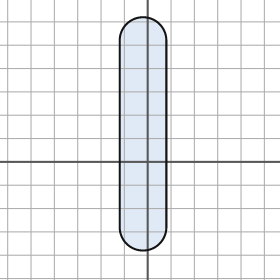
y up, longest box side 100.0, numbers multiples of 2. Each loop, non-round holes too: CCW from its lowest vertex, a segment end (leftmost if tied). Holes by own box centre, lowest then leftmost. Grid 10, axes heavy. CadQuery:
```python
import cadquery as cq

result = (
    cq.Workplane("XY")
    .moveTo(-12.0, -28.0)
    .threePointArc((-2.0, -38.0), (8.0, -28.0))
    .lineTo(8.0, 52.0)
    .threePointArc((-2.0, 62.0), (-12.0, 52.0))
    .close()
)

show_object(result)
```